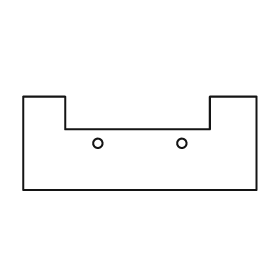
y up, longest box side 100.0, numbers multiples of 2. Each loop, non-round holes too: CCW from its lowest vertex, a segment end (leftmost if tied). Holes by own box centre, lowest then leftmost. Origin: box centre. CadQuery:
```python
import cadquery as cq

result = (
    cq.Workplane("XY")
    .moveTo(-50.0, -20.0)
    .lineTo(50.0, -20.0)
    .lineTo(50.0, 20.0)
    .lineTo(30.0, 20.0)
    .lineTo(30.0, 6.0)
    .lineTo(-32.0, 6.0)
    .lineTo(-32.0, 20.0)
    .lineTo(-50.0, 20.0)
    .close()
    .moveTo(-18.0, 0.0)
    .circle(2.0)
    .moveTo(18.0, 0.0)
    .circle(2.0)
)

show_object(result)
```